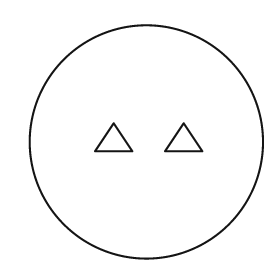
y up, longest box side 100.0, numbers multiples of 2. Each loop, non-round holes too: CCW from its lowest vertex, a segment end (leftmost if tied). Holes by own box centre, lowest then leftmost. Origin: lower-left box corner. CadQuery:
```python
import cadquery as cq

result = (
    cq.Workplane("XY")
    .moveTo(50.0, 50.0)
    .circle(50.0)
    .moveTo(28.0, 46.0)
    .lineTo(44.0, 46.0)
    .lineTo(36.0, 58.0)
    .close()
    .moveTo(58.0, 46.0)
    .lineTo(74.0, 46.0)
    .lineTo(66.0, 58.0)
    .close()
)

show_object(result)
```